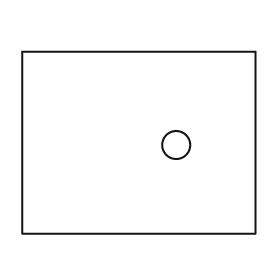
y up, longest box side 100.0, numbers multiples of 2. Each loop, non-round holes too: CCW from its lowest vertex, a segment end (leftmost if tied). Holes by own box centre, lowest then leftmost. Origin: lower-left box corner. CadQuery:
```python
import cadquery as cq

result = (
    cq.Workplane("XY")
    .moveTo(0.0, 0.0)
    .lineTo(100.0, 0.0)
    .lineTo(100.0, 78.0)
    .lineTo(0.0, 78.0)
    .close()
    .moveTo(66.0, 38.0)
    .circle(6.0)
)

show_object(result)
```